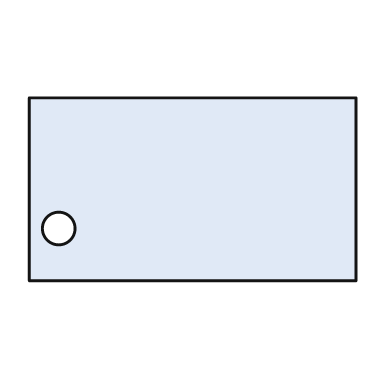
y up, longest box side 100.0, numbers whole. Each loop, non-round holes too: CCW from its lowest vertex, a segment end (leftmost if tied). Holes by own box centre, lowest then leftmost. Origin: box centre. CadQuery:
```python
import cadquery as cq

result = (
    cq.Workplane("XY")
    .moveTo(-50.0, -28.0)
    .lineTo(50.0, -28.0)
    .lineTo(50.0, 28.0)
    .lineTo(-50.0, 28.0)
    .close()
    .moveTo(-41.0, -12.0)
    .circle(5.0)
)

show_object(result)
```